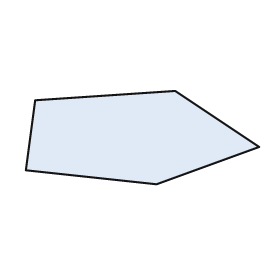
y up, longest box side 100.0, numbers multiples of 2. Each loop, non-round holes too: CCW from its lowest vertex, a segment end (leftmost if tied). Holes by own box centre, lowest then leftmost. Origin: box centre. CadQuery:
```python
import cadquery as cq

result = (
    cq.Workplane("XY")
    .moveTo(6.0, -20.0)
    .lineTo(50.0, -4.0)
    .lineTo(14.0, 20.0)
    .lineTo(-46.0, 16.0)
    .lineTo(-50.0, -14.0)
    .close()
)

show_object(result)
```